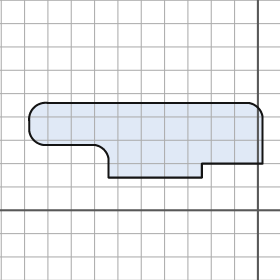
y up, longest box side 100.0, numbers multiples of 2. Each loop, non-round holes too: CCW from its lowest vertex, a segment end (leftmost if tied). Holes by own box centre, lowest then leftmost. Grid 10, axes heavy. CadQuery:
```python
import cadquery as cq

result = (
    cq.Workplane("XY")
    .moveTo(-64.0, 14.0)
    .lineTo(-24.0, 14.0)
    .lineTo(-24.0, 20.0)
    .lineTo(2.0, 20.0)
    .lineTo(2.0, 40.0)
    .threePointArc((0.0, 44.0), (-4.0, 46.0))
    .lineTo(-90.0, 46.0)
    .threePointArc((-96.0, 44.0), (-98.0, 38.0))
    .lineTo(-98.0, 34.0)
    .threePointArc((-96.0, 30.0), (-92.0, 28.0))
    .lineTo(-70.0, 28.0)
    .threePointArc((-66.0, 26.0), (-64.0, 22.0))
    .close()
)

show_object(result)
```